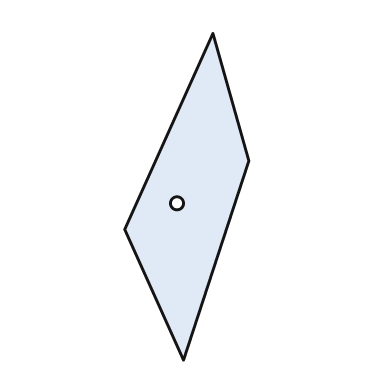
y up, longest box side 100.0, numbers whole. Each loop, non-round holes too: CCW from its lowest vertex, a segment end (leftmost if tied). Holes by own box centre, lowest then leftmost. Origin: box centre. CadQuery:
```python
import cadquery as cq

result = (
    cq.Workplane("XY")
    .moveTo(-1.0, -50.0)
    .lineTo(19.0, 11.0)
    .lineTo(8.0, 50.0)
    .lineTo(-19.0, -10.0)
    .close()
    .moveTo(-3.0, -2.0)
    .circle(2.0)
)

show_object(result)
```